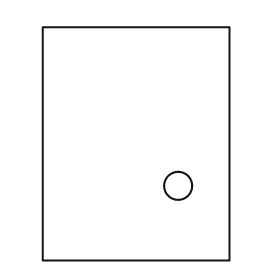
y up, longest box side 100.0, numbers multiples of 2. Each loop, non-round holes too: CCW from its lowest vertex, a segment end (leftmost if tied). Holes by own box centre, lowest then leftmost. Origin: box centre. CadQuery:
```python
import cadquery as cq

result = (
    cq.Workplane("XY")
    .moveTo(-40.0, -50.0)
    .lineTo(40.0, -50.0)
    .lineTo(40.0, 50.0)
    .lineTo(-40.0, 50.0)
    .close()
    .moveTo(18.0, -18.0)
    .circle(6.0)
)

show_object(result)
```